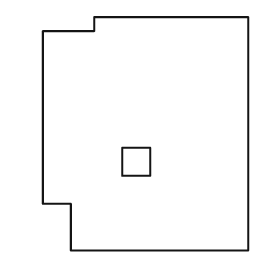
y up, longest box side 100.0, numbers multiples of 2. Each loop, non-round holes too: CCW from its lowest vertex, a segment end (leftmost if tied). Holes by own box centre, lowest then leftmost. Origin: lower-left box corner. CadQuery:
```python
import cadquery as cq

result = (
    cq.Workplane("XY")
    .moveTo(12.0, 0.0)
    .lineTo(88.0, 0.0)
    .lineTo(88.0, 100.0)
    .lineTo(22.0, 100.0)
    .lineTo(22.0, 94.0)
    .lineTo(0.0, 94.0)
    .lineTo(0.0, 20.0)
    .lineTo(12.0, 20.0)
    .close()
    .moveTo(34.0, 32.0)
    .lineTo(46.0, 32.0)
    .lineTo(46.0, 44.0)
    .lineTo(34.0, 44.0)
    .close()
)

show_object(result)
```